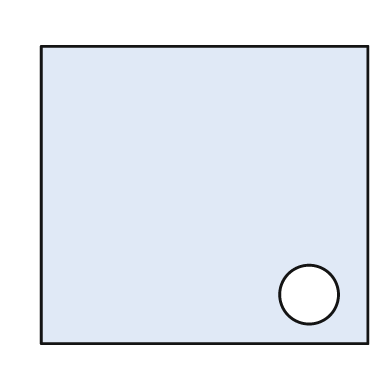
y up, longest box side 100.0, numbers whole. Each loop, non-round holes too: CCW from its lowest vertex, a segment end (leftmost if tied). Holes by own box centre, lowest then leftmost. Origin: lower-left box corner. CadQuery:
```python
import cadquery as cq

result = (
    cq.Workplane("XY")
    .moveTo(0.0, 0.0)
    .lineTo(100.0, 0.0)
    .lineTo(100.0, 91.0)
    .lineTo(0.0, 91.0)
    .close()
    .moveTo(82.0, 15.0)
    .circle(9.0)
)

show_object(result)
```